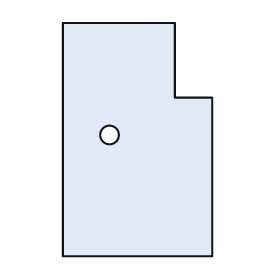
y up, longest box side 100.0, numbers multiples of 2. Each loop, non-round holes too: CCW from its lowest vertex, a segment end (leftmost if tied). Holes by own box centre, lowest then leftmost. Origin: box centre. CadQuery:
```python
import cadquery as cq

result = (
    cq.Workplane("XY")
    .moveTo(-32.0, -50.0)
    .lineTo(32.0, -50.0)
    .lineTo(32.0, 18.0)
    .lineTo(16.0, 18.0)
    .lineTo(16.0, 50.0)
    .lineTo(-32.0, 50.0)
    .close()
    .moveTo(-12.0, 2.0)
    .circle(4.0)
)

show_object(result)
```